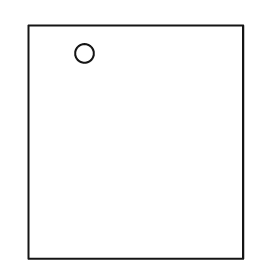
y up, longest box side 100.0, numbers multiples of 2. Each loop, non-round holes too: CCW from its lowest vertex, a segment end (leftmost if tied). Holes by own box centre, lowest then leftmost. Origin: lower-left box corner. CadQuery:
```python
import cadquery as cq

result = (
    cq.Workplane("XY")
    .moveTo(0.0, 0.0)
    .lineTo(92.0, 0.0)
    .lineTo(92.0, 100.0)
    .lineTo(0.0, 100.0)
    .close()
    .moveTo(24.0, 88.0)
    .circle(4.0)
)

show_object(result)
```